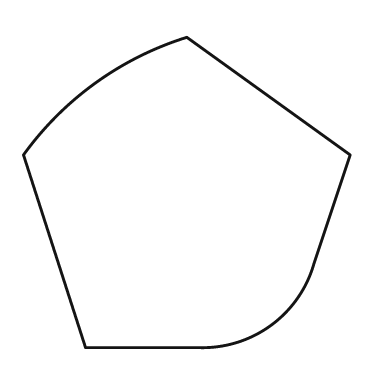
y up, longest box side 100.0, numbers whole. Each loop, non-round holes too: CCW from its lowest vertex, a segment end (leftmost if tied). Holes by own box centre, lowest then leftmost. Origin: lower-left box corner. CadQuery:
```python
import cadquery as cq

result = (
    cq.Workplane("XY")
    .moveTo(19.0, 0.0)
    .lineTo(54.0, 0.0)
    .threePointArc((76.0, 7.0), (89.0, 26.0))
    .lineTo(100.0, 59.0)
    .lineTo(50.0, 95.0)
    .threePointArc((22.0, 81.0), (0.0, 59.0))
    .close()
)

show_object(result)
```